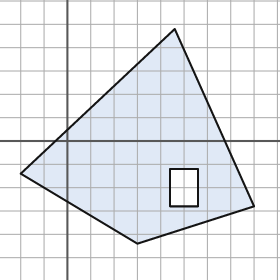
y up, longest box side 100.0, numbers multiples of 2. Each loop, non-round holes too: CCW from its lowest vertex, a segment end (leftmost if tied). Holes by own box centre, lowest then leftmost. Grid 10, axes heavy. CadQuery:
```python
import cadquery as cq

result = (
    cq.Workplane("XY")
    .moveTo(30.0, -44.0)
    .lineTo(80.0, -28.0)
    .lineTo(46.0, 48.0)
    .lineTo(-20.0, -14.0)
    .close()
    .moveTo(44.0, -28.0)
    .lineTo(56.0, -28.0)
    .lineTo(56.0, -12.0)
    .lineTo(44.0, -12.0)
    .close()
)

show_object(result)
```